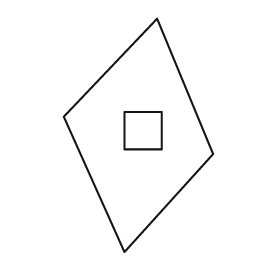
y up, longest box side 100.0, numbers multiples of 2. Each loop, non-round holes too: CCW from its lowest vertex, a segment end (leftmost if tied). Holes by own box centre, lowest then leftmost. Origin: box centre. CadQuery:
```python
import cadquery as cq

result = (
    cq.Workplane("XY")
    .moveTo(-6.0, -50.0)
    .lineTo(32.0, -8.0)
    .lineTo(8.0, 50.0)
    .lineTo(-32.0, 8.0)
    .close()
    .moveTo(-6.0, -6.0)
    .lineTo(10.0, -6.0)
    .lineTo(10.0, 10.0)
    .lineTo(-6.0, 10.0)
    .close()
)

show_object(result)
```